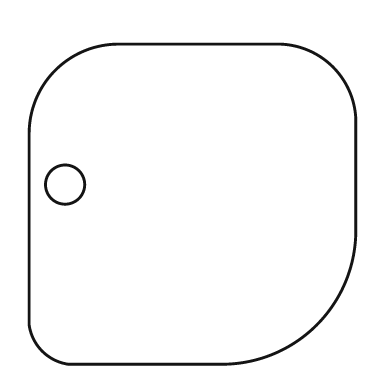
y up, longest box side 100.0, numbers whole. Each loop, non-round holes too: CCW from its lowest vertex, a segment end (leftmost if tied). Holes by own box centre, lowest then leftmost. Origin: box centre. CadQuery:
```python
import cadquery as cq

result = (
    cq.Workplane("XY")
    .moveTo(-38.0, -49.0)
    .lineTo(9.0, -49.0)
    .threePointArc((38.0, -37.0), (50.0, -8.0))
    .lineTo(50.0, 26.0)
    .threePointArc((43.0, 42.0), (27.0, 49.0))
    .lineTo(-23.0, 49.0)
    .threePointArc((-42.0, 41.0), (-50.0, 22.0))
    .lineTo(-50.0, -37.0)
    .threePointArc((-46.0, -45.0), (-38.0, -49.0))
    .close()
    .moveTo(-39.0, 6.0)
    .circle(6.0)
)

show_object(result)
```